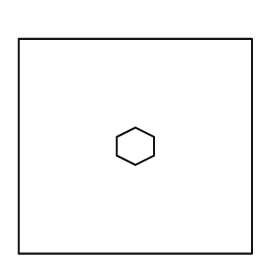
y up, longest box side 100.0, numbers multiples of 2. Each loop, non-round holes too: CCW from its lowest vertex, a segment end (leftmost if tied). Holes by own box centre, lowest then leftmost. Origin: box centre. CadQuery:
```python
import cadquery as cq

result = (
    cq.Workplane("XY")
    .moveTo(-50.0, -46.0)
    .lineTo(50.0, -46.0)
    .lineTo(50.0, 46.0)
    .lineTo(-50.0, 46.0)
    .close()
    .moveTo(0.0, -8.0)
    .lineTo(8.0, -4.0)
    .lineTo(8.0, 4.0)
    .lineTo(0.0, 8.0)
    .lineTo(-8.0, 4.0)
    .lineTo(-8.0, -4.0)
    .close()
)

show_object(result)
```